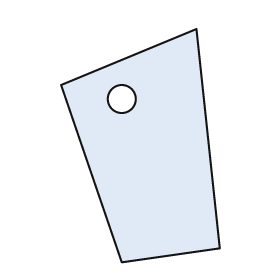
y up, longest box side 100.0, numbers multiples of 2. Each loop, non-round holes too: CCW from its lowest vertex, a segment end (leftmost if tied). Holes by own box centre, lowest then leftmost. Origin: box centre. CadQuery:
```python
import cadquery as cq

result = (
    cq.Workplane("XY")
    .moveTo(-8.0, -50.0)
    .lineTo(34.0, -44.0)
    .lineTo(24.0, 50.0)
    .lineTo(-34.0, 26.0)
    .close()
    .moveTo(-8.0, 20.0)
    .circle(6.0)
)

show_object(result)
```